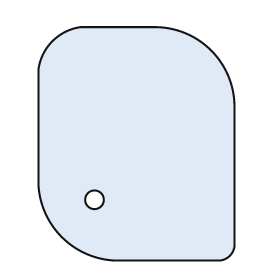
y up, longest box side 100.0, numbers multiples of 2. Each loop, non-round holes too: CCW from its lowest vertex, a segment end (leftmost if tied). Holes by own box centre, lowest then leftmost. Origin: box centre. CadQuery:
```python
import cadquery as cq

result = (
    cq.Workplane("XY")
    .moveTo(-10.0, -50.0)
    .lineTo(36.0, -50.0)
    .threePointArc((40.0, -48.0), (42.0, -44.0))
    .lineTo(42.0, 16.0)
    .threePointArc((32.0, 40.0), (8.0, 50.0))
    .lineTo(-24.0, 50.0)
    .threePointArc((-36.0, 44.0), (-42.0, 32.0))
    .lineTo(-42.0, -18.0)
    .threePointArc((-32.0, -40.0), (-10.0, -50.0))
    .close()
    .moveTo(-18.0, -24.0)
    .circle(4.0)
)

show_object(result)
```